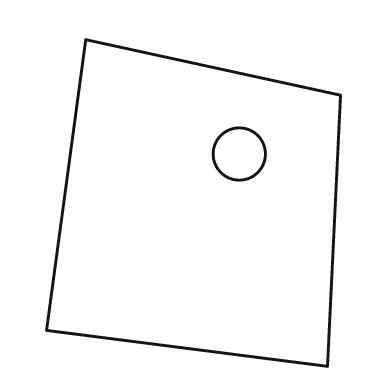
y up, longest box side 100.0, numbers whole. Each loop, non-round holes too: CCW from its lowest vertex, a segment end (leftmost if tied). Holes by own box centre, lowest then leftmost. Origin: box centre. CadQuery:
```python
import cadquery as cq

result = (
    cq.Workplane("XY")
    .moveTo(41.0, -50.0)
    .lineTo(45.0, 33.0)
    .lineTo(-33.0, 50.0)
    .lineTo(-45.0, -39.0)
    .close()
    .moveTo(14.0, 15.0)
    .circle(8.0)
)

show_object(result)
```